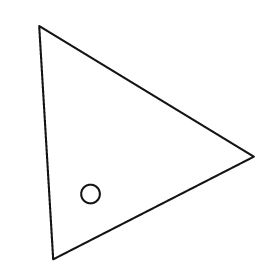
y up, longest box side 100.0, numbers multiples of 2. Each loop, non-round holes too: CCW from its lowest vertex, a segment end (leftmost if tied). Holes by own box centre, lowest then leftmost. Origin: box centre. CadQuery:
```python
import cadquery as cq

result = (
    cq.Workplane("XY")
    .moveTo(-40.0, -50.0)
    .lineTo(46.0, -6.0)
    .lineTo(-46.0, 50.0)
    .close()
    .moveTo(-24.0, -22.0)
    .circle(4.0)
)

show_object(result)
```